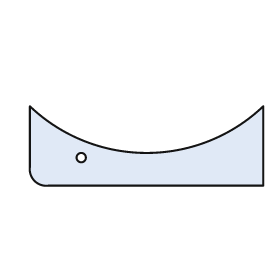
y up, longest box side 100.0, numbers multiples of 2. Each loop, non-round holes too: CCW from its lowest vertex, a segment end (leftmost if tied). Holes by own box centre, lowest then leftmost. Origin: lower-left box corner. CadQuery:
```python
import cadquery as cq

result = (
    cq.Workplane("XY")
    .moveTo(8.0, 0.0)
    .lineTo(100.0, 0.0)
    .lineTo(100.0, 34.0)
    .threePointArc((50.0, 14.0), (0.0, 34.0))
    .lineTo(0.0, 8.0)
    .threePointArc((2.0, 2.0), (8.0, 0.0))
    .close()
    .moveTo(22.0, 12.0)
    .circle(2.0)
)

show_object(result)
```